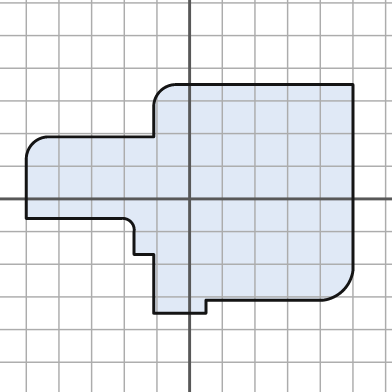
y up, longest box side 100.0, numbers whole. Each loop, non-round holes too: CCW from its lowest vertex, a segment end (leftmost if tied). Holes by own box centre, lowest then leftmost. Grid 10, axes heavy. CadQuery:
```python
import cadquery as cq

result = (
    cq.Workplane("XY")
    .moveTo(-11.0, -35.0)
    .lineTo(5.0, -35.0)
    .lineTo(5.0, -31.0)
    .lineTo(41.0, -31.0)
    .threePointArc((47.0, -28.0), (50.0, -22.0))
    .lineTo(50.0, 35.0)
    .lineTo(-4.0, 35.0)
    .threePointArc((-9.0, 33.0), (-11.0, 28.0))
    .lineTo(-11.0, 19.0)
    .lineTo(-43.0, 19.0)
    .threePointArc((-48.0, 17.0), (-50.0, 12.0))
    .lineTo(-50.0, -6.0)
    .lineTo(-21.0, -6.0)
    .threePointArc((-18.0, -7.0), (-17.0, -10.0))
    .lineTo(-17.0, -17.0)
    .lineTo(-11.0, -17.0)
    .close()
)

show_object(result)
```